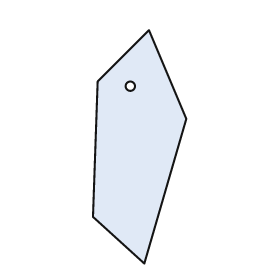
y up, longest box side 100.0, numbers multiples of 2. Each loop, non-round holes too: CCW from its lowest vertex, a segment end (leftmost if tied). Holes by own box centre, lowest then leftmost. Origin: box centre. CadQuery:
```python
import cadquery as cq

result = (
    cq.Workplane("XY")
    .moveTo(2.0, -50.0)
    .lineTo(20.0, 12.0)
    .lineTo(4.0, 50.0)
    .lineTo(-18.0, 28.0)
    .lineTo(-20.0, -30.0)
    .close()
    .moveTo(-4.0, 26.0)
    .circle(2.0)
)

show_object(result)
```